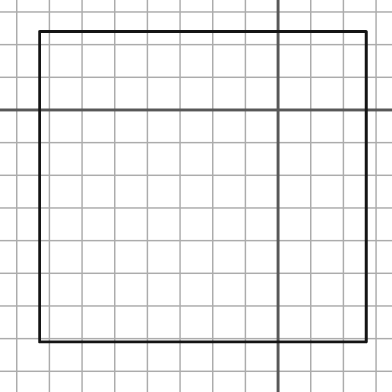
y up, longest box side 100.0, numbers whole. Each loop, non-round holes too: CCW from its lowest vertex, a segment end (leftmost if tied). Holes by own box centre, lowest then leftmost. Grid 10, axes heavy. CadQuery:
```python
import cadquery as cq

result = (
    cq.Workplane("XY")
    .moveTo(-73.0, -71.0)
    .lineTo(27.0, -71.0)
    .lineTo(27.0, 24.0)
    .lineTo(-73.0, 24.0)
    .close()
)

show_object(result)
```